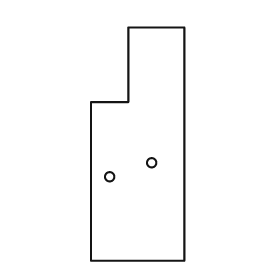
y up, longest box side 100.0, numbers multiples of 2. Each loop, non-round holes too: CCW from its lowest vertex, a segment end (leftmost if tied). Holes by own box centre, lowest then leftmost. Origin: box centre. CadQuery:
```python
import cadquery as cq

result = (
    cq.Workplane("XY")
    .moveTo(-20.0, -50.0)
    .lineTo(20.0, -50.0)
    .lineTo(20.0, 50.0)
    .lineTo(-4.0, 50.0)
    .lineTo(-4.0, 18.0)
    .lineTo(-20.0, 18.0)
    .close()
    .moveTo(-12.0, -14.0)
    .circle(2.0)
    .moveTo(6.0, -8.0)
    .circle(2.0)
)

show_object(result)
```